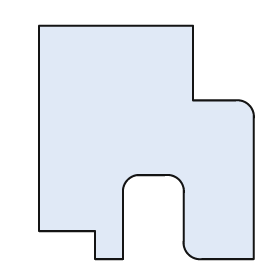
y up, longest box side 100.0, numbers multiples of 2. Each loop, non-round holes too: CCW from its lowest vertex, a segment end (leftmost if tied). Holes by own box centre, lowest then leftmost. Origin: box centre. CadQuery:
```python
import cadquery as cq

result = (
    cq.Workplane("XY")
    .moveTo(-22.0, -50.0)
    .lineTo(-10.0, -50.0)
    .lineTo(-10.0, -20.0)
    .threePointArc((-8.0, -16.0), (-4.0, -14.0))
    .lineTo(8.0, -14.0)
    .threePointArc((14.0, -16.0), (16.0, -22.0))
    .lineTo(16.0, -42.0)
    .threePointArc((18.0, -48.0), (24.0, -50.0))
    .lineTo(46.0, -50.0)
    .lineTo(46.0, 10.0)
    .threePointArc((44.0, 16.0), (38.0, 18.0))
    .lineTo(20.0, 18.0)
    .lineTo(20.0, 50.0)
    .lineTo(-46.0, 50.0)
    .lineTo(-46.0, -38.0)
    .lineTo(-22.0, -38.0)
    .close()
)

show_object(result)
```